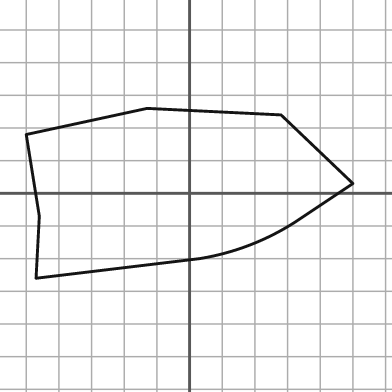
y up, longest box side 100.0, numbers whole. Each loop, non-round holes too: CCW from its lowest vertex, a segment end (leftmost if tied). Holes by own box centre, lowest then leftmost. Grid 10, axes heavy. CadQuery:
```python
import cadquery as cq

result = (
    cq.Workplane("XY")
    .moveTo(-47.0, -26.0)
    .lineTo(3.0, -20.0)
    .threePointArc((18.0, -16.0), (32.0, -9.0))
    .lineTo(50.0, 3.0)
    .lineTo(28.0, 24.0)
    .lineTo(-13.0, 26.0)
    .lineTo(-50.0, 18.0)
    .lineTo(-46.0, -7.0)
    .close()
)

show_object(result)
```